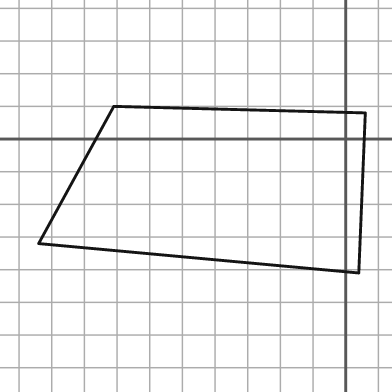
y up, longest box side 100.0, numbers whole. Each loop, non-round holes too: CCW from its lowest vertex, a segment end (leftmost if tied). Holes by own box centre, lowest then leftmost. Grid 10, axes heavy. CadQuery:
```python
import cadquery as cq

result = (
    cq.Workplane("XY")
    .moveTo(4.0, -41.0)
    .lineTo(6.0, 8.0)
    .lineTo(-71.0, 10.0)
    .lineTo(-94.0, -32.0)
    .close()
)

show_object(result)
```